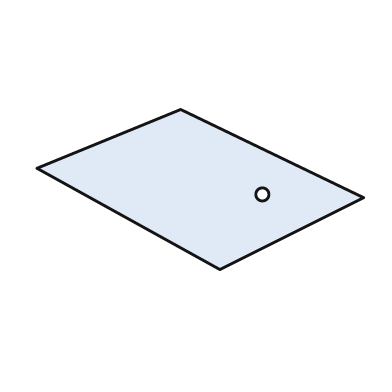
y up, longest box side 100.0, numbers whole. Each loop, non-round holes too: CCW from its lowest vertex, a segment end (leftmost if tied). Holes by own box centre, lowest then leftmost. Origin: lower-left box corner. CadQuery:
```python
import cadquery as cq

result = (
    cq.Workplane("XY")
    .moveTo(56.0, 0.0)
    .lineTo(100.0, 22.0)
    .lineTo(44.0, 49.0)
    .lineTo(0.0, 31.0)
    .close()
    .moveTo(69.0, 23.0)
    .circle(2.0)
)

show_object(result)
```